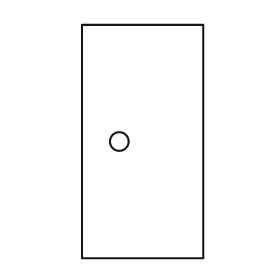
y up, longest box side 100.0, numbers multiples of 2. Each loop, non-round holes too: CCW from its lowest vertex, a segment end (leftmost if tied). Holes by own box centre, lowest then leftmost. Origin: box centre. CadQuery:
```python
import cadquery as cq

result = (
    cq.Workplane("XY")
    .moveTo(-26.0, -50.0)
    .lineTo(26.0, -50.0)
    .lineTo(26.0, 50.0)
    .lineTo(-26.0, 50.0)
    .close()
    .moveTo(-10.0, 0.0)
    .circle(4.0)
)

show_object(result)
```